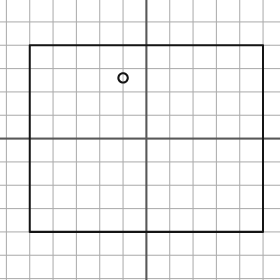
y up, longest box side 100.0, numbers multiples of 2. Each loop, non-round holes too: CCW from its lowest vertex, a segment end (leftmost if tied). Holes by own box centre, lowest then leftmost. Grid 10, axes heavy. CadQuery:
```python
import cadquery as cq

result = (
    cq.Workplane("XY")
    .moveTo(-50.0, -40.0)
    .lineTo(50.0, -40.0)
    .lineTo(50.0, 40.0)
    .lineTo(-50.0, 40.0)
    .close()
    .moveTo(-10.0, 26.0)
    .circle(2.0)
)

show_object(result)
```